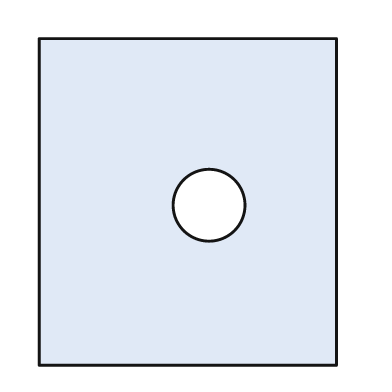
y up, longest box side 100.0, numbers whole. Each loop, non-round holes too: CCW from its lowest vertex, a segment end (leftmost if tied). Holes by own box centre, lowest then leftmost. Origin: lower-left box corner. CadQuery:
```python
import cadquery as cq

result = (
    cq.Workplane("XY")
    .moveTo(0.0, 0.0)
    .lineTo(91.0, 0.0)
    .lineTo(91.0, 100.0)
    .lineTo(0.0, 100.0)
    .close()
    .moveTo(52.0, 49.0)
    .circle(11.0)
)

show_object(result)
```